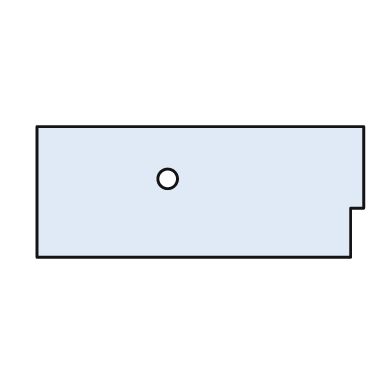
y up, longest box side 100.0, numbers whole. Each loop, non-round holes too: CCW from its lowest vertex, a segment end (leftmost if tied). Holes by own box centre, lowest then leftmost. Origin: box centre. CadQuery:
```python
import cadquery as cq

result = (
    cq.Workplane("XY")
    .moveTo(-50.0, -20.0)
    .lineTo(46.0, -20.0)
    .lineTo(46.0, -5.0)
    .lineTo(50.0, -5.0)
    .lineTo(50.0, 20.0)
    .lineTo(-50.0, 20.0)
    .close()
    .moveTo(-10.0, 4.0)
    .circle(3.0)
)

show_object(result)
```